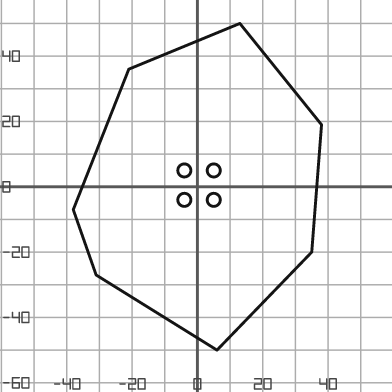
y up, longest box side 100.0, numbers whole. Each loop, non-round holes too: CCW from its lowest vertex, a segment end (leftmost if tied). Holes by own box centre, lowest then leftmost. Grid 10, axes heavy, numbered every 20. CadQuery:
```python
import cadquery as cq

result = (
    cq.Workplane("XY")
    .moveTo(6.0, -50.0)
    .lineTo(35.0, -20.0)
    .lineTo(38.0, 19.0)
    .lineTo(13.0, 50.0)
    .lineTo(-21.0, 36.0)
    .lineTo(-38.0, -7.0)
    .lineTo(-31.0, -27.0)
    .close()
    .moveTo(-4.0, -4.0)
    .circle(2.0)
    .moveTo(5.0, -4.0)
    .circle(2.0)
    .moveTo(-4.0, 5.0)
    .circle(2.0)
    .moveTo(5.0, 5.0)
    .circle(2.0)
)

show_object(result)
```